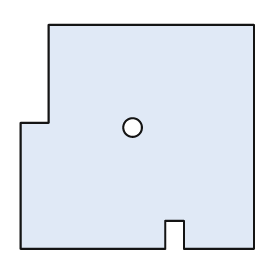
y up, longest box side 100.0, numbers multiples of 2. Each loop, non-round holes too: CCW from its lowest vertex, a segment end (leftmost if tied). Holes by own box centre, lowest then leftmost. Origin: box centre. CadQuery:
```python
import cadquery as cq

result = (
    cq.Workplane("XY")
    .moveTo(-50.0, -48.0)
    .lineTo(12.0, -48.0)
    .lineTo(12.0, -36.0)
    .lineTo(20.0, -36.0)
    .lineTo(20.0, -48.0)
    .lineTo(50.0, -48.0)
    .lineTo(50.0, 48.0)
    .lineTo(-38.0, 48.0)
    .lineTo(-38.0, 6.0)
    .lineTo(-50.0, 6.0)
    .close()
    .moveTo(-2.0, 4.0)
    .circle(4.0)
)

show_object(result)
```